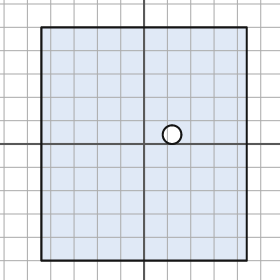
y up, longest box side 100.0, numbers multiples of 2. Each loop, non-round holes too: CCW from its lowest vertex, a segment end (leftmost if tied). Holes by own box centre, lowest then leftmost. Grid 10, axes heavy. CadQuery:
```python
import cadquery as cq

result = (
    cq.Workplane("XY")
    .moveTo(-44.0, -50.0)
    .lineTo(44.0, -50.0)
    .lineTo(44.0, 50.0)
    .lineTo(-44.0, 50.0)
    .close()
    .moveTo(12.0, 4.0)
    .circle(4.0)
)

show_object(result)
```